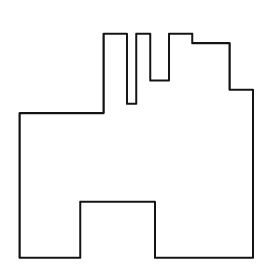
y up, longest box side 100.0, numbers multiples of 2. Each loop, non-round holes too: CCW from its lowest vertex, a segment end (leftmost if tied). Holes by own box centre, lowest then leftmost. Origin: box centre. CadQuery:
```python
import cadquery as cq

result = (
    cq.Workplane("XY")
    .moveTo(-50.0, -48.0)
    .lineTo(-24.0, -48.0)
    .lineTo(-24.0, -24.0)
    .lineTo(8.0, -24.0)
    .lineTo(8.0, -48.0)
    .lineTo(50.0, -48.0)
    .lineTo(50.0, 24.0)
    .lineTo(40.0, 24.0)
    .lineTo(40.0, 44.0)
    .lineTo(24.0, 44.0)
    .lineTo(24.0, 48.0)
    .lineTo(14.0, 48.0)
    .lineTo(14.0, 28.0)
    .lineTo(6.0, 28.0)
    .lineTo(6.0, 48.0)
    .lineTo(0.0, 48.0)
    .lineTo(0.0, 18.0)
    .lineTo(-4.0, 18.0)
    .lineTo(-4.0, 48.0)
    .lineTo(-14.0, 48.0)
    .lineTo(-14.0, 14.0)
    .lineTo(-50.0, 14.0)
    .close()
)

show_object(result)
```